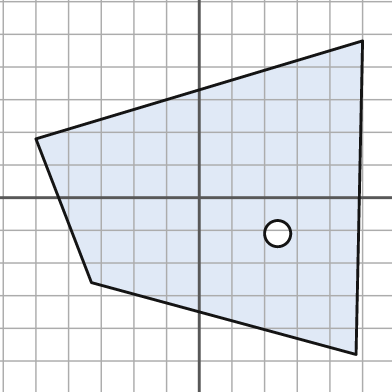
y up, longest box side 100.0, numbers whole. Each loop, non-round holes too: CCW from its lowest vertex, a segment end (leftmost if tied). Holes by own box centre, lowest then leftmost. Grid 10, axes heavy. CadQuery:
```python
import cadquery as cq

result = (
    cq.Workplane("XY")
    .moveTo(48.0, -48.0)
    .lineTo(50.0, 48.0)
    .lineTo(-50.0, 18.0)
    .lineTo(-33.0, -26.0)
    .close()
    .moveTo(24.0, -11.0)
    .circle(4.0)
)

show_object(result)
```